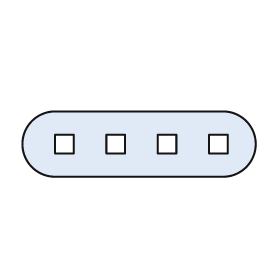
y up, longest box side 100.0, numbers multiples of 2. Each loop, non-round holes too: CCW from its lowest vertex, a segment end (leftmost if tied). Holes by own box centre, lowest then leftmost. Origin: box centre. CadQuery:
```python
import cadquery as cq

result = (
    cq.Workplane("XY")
    .moveTo(-36.0, -14.0)
    .lineTo(36.0, -14.0)
    .threePointArc((50.0, 0.0), (36.0, 14.0))
    .lineTo(-36.0, 14.0)
    .threePointArc((-50.0, 0.0), (-36.0, -14.0))
    .close()
    .moveTo(-36.0, -4.0)
    .lineTo(-28.0, -4.0)
    .lineTo(-28.0, 4.0)
    .lineTo(-36.0, 4.0)
    .close()
    .moveTo(-14.0, -4.0)
    .lineTo(-6.0, -4.0)
    .lineTo(-6.0, 4.0)
    .lineTo(-14.0, 4.0)
    .close()
    .moveTo(8.0, -4.0)
    .lineTo(16.0, -4.0)
    .lineTo(16.0, 4.0)
    .lineTo(8.0, 4.0)
    .close()
    .moveTo(30.0, -4.0)
    .lineTo(38.0, -4.0)
    .lineTo(38.0, 4.0)
    .lineTo(30.0, 4.0)
    .close()
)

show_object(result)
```